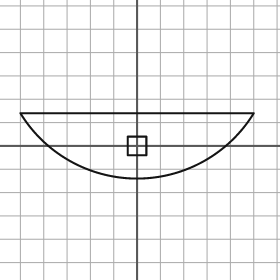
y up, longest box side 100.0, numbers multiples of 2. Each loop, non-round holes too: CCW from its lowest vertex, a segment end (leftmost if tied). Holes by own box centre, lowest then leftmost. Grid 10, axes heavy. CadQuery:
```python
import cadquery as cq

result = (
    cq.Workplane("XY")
    .moveTo(-50.0, 14.0)
    .threePointArc((0.0, -14.0), (50.0, 14.0))
    .close()
    .moveTo(-4.0, -4.0)
    .lineTo(4.0, -4.0)
    .lineTo(4.0, 4.0)
    .lineTo(-4.0, 4.0)
    .close()
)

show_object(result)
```